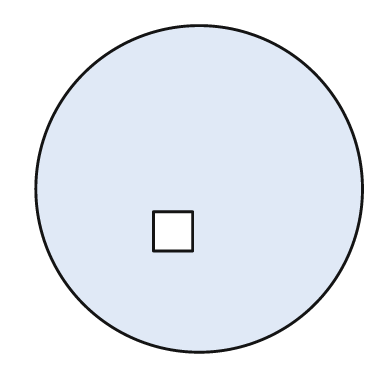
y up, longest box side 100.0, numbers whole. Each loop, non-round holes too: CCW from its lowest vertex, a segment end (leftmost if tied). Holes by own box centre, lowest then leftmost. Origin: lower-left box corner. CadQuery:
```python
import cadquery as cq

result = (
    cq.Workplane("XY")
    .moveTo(50.0, 50.0)
    .circle(50.0)
    .moveTo(36.0, 31.0)
    .lineTo(48.0, 31.0)
    .lineTo(48.0, 43.0)
    .lineTo(36.0, 43.0)
    .close()
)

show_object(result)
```